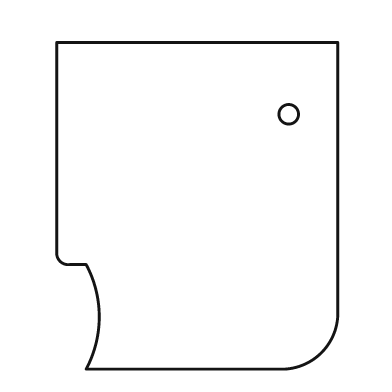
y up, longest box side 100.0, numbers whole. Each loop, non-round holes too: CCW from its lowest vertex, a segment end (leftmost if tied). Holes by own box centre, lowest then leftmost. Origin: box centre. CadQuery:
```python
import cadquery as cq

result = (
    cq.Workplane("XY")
    .moveTo(-34.0, -50.0)
    .lineTo(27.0, -50.0)
    .threePointArc((38.0, -45.0), (43.0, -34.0))
    .lineTo(43.0, 50.0)
    .lineTo(-43.0, 50.0)
    .lineTo(-43.0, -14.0)
    .threePointArc((-42.0, -17.0), (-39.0, -18.0))
    .lineTo(-34.0, -18.0)
    .threePointArc((-30.0, -34.0), (-34.0, -50.0))
    .close()
    .moveTo(28.0, 28.0)
    .circle(3.0)
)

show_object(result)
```